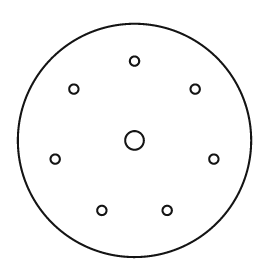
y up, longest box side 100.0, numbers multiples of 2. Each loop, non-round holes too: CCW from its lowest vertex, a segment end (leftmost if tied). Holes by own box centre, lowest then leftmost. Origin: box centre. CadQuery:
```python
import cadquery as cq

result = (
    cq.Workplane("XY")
    .moveTo(0.0, 0.0)
    .circle(50.0)
    .moveTo(-14.0, -30.0)
    .circle(2.0)
    .moveTo(14.0, -30.0)
    .circle(2.0)
    .moveTo(-34.0, -8.0)
    .circle(2.0)
    .moveTo(34.0, -8.0)
    .circle(2.0)
    .moveTo(0.0, 0.0)
    .circle(4.0)
    .moveTo(-26.0, 22.0)
    .circle(2.0)
    .moveTo(26.0, 22.0)
    .circle(2.0)
    .moveTo(0.0, 34.0)
    .circle(2.0)
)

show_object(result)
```